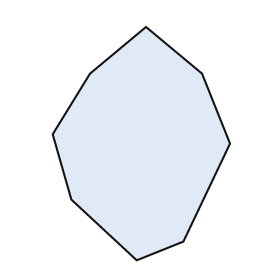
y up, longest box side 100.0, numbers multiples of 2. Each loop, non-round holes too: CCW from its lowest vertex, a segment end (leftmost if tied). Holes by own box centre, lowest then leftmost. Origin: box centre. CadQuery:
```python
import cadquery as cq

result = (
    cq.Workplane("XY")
    .moveTo(-2.0, -50.0)
    .lineTo(18.0, -42.0)
    .lineTo(38.0, 0.0)
    .lineTo(26.0, 30.0)
    .lineTo(2.0, 50.0)
    .lineTo(-22.0, 30.0)
    .lineTo(-38.0, 4.0)
    .lineTo(-30.0, -24.0)
    .close()
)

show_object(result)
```